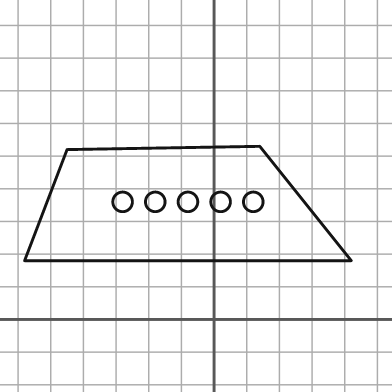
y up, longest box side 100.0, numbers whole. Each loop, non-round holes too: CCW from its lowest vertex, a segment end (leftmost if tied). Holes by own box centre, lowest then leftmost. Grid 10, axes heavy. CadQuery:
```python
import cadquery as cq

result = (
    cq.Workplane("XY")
    .moveTo(-58.0, 18.0)
    .lineTo(42.0, 18.0)
    .lineTo(14.0, 53.0)
    .lineTo(-45.0, 52.0)
    .close()
    .moveTo(-28.0, 36.0)
    .circle(3.0)
    .moveTo(-18.0, 36.0)
    .circle(3.0)
    .moveTo(-8.0, 36.0)
    .circle(3.0)
    .moveTo(2.0, 36.0)
    .circle(3.0)
    .moveTo(12.0, 36.0)
    .circle(3.0)
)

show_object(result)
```